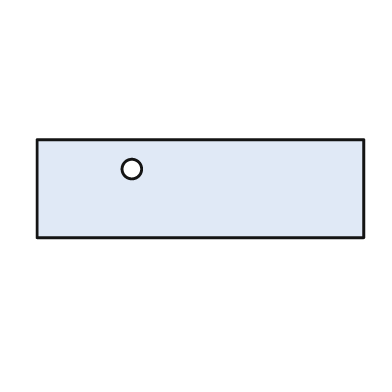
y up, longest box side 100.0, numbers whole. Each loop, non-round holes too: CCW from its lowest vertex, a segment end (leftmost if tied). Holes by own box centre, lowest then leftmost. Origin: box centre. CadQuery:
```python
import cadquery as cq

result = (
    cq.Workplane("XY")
    .moveTo(-50.0, -15.0)
    .lineTo(50.0, -15.0)
    .lineTo(50.0, 15.0)
    .lineTo(-50.0, 15.0)
    .close()
    .moveTo(-21.0, 6.0)
    .circle(3.0)
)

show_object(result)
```